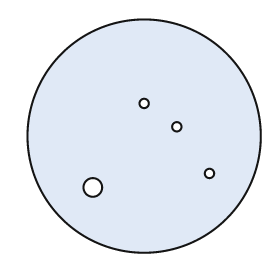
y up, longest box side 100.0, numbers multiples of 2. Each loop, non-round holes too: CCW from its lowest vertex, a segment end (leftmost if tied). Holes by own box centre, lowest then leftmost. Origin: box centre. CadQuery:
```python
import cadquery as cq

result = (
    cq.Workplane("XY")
    .moveTo(0.0, 0.0)
    .circle(50.0)
    .moveTo(-22.0, -22.0)
    .circle(4.0)
    .moveTo(28.0, -16.0)
    .circle(2.0)
    .moveTo(14.0, 4.0)
    .circle(2.0)
    .moveTo(0.0, 14.0)
    .circle(2.0)
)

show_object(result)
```